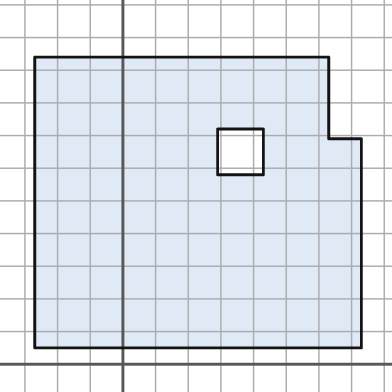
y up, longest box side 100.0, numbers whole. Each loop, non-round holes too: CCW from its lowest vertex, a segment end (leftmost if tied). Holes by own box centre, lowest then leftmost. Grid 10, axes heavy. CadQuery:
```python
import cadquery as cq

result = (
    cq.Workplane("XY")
    .moveTo(-27.0, 5.0)
    .lineTo(73.0, 5.0)
    .lineTo(73.0, 69.0)
    .lineTo(63.0, 69.0)
    .lineTo(63.0, 94.0)
    .lineTo(-27.0, 94.0)
    .close()
    .moveTo(29.0, 58.0)
    .lineTo(43.0, 58.0)
    .lineTo(43.0, 72.0)
    .lineTo(29.0, 72.0)
    .close()
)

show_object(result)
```